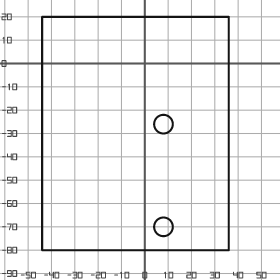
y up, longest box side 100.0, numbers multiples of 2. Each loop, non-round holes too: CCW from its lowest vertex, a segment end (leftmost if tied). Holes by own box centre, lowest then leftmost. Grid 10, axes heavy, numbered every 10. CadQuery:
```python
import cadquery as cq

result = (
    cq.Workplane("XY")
    .moveTo(-44.0, -80.0)
    .lineTo(36.0, -80.0)
    .lineTo(36.0, 20.0)
    .lineTo(-44.0, 20.0)
    .close()
    .moveTo(8.0, -70.0)
    .circle(4.0)
    .moveTo(8.0, -26.0)
    .circle(4.0)
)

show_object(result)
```